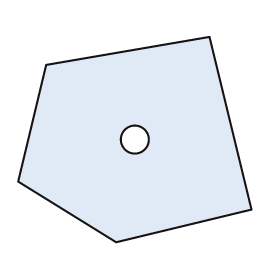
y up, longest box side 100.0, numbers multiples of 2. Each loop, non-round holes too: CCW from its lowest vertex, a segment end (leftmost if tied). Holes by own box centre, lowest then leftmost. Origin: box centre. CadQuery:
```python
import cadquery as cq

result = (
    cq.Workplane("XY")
    .moveTo(-8.0, -44.0)
    .lineTo(50.0, -30.0)
    .lineTo(32.0, 44.0)
    .lineTo(-38.0, 32.0)
    .lineTo(-50.0, -18.0)
    .close()
    .moveTo(0.0, 0.0)
    .circle(6.0)
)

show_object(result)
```